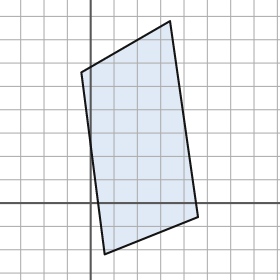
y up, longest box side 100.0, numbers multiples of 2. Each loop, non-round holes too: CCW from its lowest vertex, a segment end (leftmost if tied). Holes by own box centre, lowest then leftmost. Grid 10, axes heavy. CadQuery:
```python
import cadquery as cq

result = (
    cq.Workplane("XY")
    .moveTo(6.0, -22.0)
    .lineTo(46.0, -6.0)
    .lineTo(34.0, 78.0)
    .lineTo(-4.0, 56.0)
    .close()
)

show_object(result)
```